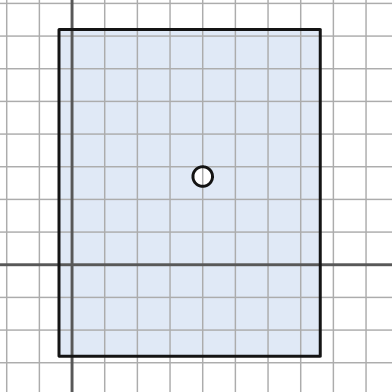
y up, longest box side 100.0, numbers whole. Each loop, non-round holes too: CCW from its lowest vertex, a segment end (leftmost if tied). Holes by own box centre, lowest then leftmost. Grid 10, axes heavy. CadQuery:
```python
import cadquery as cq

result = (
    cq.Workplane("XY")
    .moveTo(-4.0, -28.0)
    .lineTo(76.0, -28.0)
    .lineTo(76.0, 72.0)
    .lineTo(-4.0, 72.0)
    .close()
    .moveTo(40.0, 27.0)
    .circle(3.0)
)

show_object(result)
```